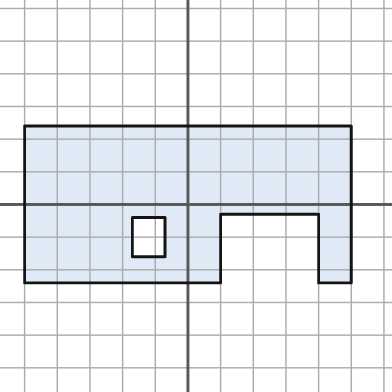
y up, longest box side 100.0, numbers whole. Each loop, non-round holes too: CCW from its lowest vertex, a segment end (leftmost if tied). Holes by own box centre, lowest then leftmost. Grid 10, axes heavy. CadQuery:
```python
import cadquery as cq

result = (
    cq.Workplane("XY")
    .moveTo(-50.0, -24.0)
    .lineTo(10.0, -24.0)
    .lineTo(10.0, -3.0)
    .lineTo(40.0, -3.0)
    .lineTo(40.0, -24.0)
    .lineTo(50.0, -24.0)
    .lineTo(50.0, 24.0)
    .lineTo(-50.0, 24.0)
    .close()
    .moveTo(-17.0, -16.0)
    .lineTo(-7.0, -16.0)
    .lineTo(-7.0, -4.0)
    .lineTo(-17.0, -4.0)
    .close()
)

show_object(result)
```